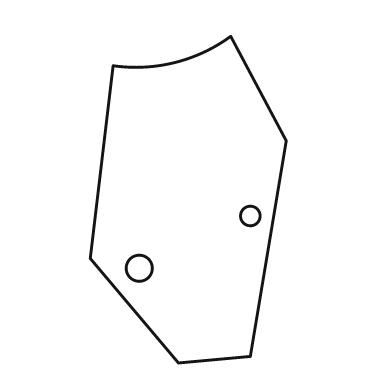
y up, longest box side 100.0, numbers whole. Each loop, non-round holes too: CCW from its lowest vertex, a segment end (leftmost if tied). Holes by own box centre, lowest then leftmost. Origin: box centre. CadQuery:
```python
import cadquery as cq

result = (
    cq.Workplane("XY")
    .moveTo(-3.0, -50.0)
    .lineTo(19.0, -48.0)
    .lineTo(30.0, 18.0)
    .lineTo(13.0, 50.0)
    .threePointArc((-4.0, 42.0), (-23.0, 41.0))
    .lineTo(-30.0, -18.0)
    .close()
    .moveTo(-15.0, -21.0)
    .circle(4.0)
    .moveTo(19.0, -5.0)
    .circle(3.0)
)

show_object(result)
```